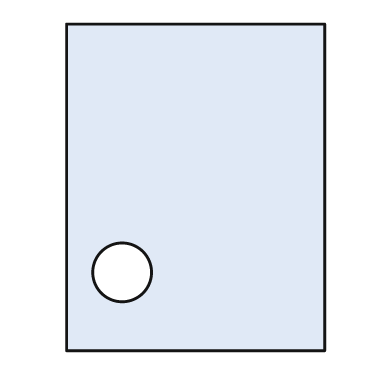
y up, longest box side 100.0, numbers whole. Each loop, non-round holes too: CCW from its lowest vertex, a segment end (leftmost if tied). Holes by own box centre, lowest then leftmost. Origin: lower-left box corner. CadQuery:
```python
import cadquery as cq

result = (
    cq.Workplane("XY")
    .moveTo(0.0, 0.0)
    .lineTo(79.0, 0.0)
    .lineTo(79.0, 100.0)
    .lineTo(0.0, 100.0)
    .close()
    .moveTo(17.0, 24.0)
    .circle(9.0)
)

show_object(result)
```